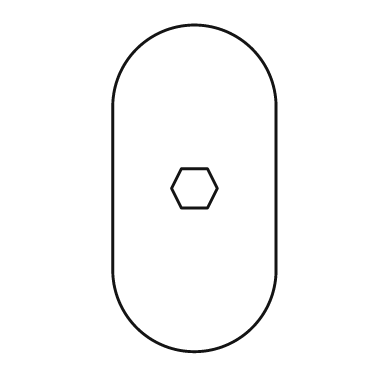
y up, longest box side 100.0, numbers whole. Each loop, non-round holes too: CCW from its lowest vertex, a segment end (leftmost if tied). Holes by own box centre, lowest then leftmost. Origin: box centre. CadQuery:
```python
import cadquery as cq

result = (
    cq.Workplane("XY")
    .moveTo(-25.0, -25.0)
    .threePointArc((0.0, -50.0), (25.0, -25.0))
    .lineTo(25.0, 25.0)
    .threePointArc((0.0, 50.0), (-25.0, 25.0))
    .close()
    .moveTo(-4.0, -6.0)
    .lineTo(4.0, -6.0)
    .lineTo(7.0, 0.0)
    .lineTo(4.0, 6.0)
    .lineTo(-4.0, 6.0)
    .lineTo(-7.0, 0.0)
    .close()
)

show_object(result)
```